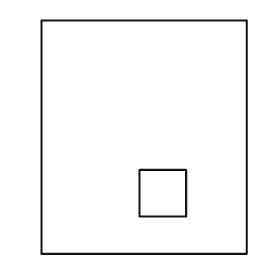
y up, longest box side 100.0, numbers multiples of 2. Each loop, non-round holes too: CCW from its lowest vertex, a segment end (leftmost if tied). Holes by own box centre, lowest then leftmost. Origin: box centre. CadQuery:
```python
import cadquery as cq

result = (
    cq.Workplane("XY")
    .moveTo(-44.0, -50.0)
    .lineTo(44.0, -50.0)
    .lineTo(44.0, 50.0)
    .lineTo(-44.0, 50.0)
    .close()
    .moveTo(-2.0, -34.0)
    .lineTo(18.0, -34.0)
    .lineTo(18.0, -14.0)
    .lineTo(-2.0, -14.0)
    .close()
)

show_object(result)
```